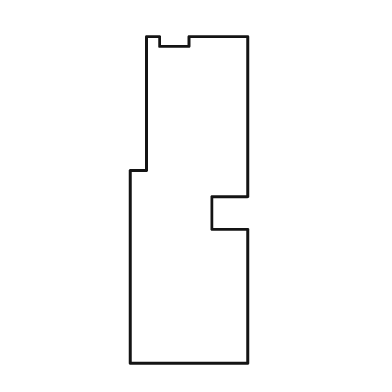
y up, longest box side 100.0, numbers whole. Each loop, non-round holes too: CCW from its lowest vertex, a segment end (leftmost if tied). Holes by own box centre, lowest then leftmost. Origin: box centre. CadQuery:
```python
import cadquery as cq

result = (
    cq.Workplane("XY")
    .moveTo(-18.0, -50.0)
    .lineTo(18.0, -50.0)
    .lineTo(18.0, -9.0)
    .lineTo(7.0, -9.0)
    .lineTo(7.0, 1.0)
    .lineTo(18.0, 1.0)
    .lineTo(18.0, 50.0)
    .lineTo(0.0, 50.0)
    .lineTo(0.0, 47.0)
    .lineTo(-9.0, 47.0)
    .lineTo(-9.0, 50.0)
    .lineTo(-13.0, 50.0)
    .lineTo(-13.0, 9.0)
    .lineTo(-18.0, 9.0)
    .close()
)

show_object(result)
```